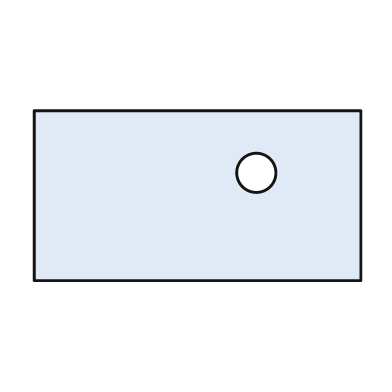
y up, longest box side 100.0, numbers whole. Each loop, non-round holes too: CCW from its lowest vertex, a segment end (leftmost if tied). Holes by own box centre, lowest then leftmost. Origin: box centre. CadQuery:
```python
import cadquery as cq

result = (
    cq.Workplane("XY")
    .moveTo(-50.0, -26.0)
    .lineTo(50.0, -26.0)
    .lineTo(50.0, 26.0)
    .lineTo(-50.0, 26.0)
    .close()
    .moveTo(18.0, 7.0)
    .circle(6.0)
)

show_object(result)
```